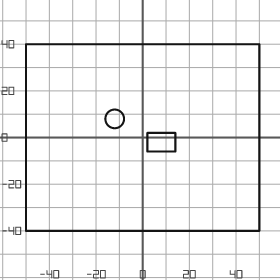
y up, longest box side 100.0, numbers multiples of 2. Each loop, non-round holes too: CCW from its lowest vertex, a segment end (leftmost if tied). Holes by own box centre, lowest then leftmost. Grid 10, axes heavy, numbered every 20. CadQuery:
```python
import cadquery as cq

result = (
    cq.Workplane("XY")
    .moveTo(-50.0, -40.0)
    .lineTo(50.0, -40.0)
    .lineTo(50.0, 40.0)
    .lineTo(-50.0, 40.0)
    .close()
    .moveTo(2.0, -6.0)
    .lineTo(14.0, -6.0)
    .lineTo(14.0, 2.0)
    .lineTo(2.0, 2.0)
    .close()
    .moveTo(-12.0, 8.0)
    .circle(4.0)
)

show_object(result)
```